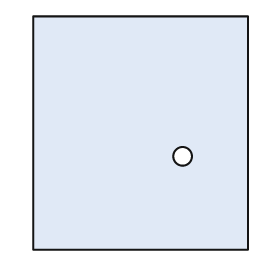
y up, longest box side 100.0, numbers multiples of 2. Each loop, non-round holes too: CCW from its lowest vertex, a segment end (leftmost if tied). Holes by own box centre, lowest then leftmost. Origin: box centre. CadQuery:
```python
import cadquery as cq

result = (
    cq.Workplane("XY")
    .moveTo(-46.0, -50.0)
    .lineTo(46.0, -50.0)
    .lineTo(46.0, 50.0)
    .lineTo(-46.0, 50.0)
    .close()
    .moveTo(18.0, -10.0)
    .circle(4.0)
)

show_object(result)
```